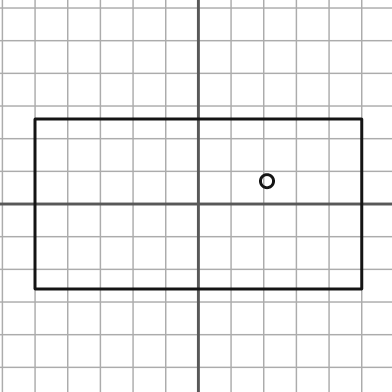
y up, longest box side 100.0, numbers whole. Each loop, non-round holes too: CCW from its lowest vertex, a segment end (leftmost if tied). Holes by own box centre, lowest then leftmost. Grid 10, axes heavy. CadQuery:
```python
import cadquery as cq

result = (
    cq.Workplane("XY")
    .moveTo(-50.0, -26.0)
    .lineTo(50.0, -26.0)
    .lineTo(50.0, 26.0)
    .lineTo(-50.0, 26.0)
    .close()
    .moveTo(21.0, 7.0)
    .circle(2.0)
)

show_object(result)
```